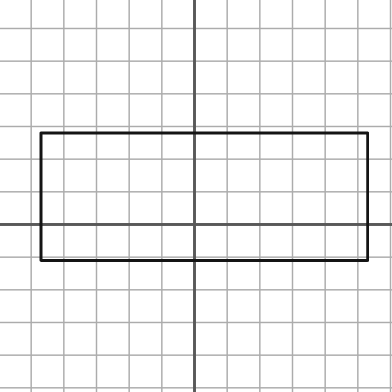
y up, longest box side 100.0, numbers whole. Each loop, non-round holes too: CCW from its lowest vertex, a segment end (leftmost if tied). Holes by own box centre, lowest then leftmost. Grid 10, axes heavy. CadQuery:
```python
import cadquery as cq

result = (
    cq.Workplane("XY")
    .moveTo(-47.0, -11.0)
    .lineTo(53.0, -11.0)
    .lineTo(53.0, 28.0)
    .lineTo(-47.0, 28.0)
    .close()
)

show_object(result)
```